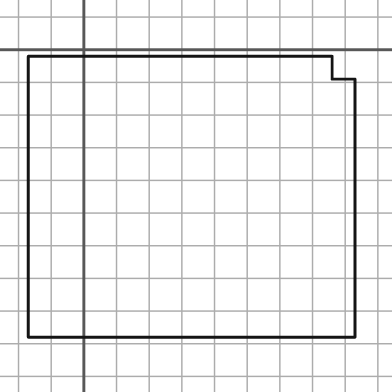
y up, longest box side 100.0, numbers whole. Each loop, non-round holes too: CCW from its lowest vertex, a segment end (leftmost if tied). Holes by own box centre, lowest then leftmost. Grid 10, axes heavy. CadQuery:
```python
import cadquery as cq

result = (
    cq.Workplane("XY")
    .moveTo(-17.0, -88.0)
    .lineTo(83.0, -88.0)
    .lineTo(83.0, -9.0)
    .lineTo(76.0, -9.0)
    .lineTo(76.0, -2.0)
    .lineTo(-17.0, -2.0)
    .close()
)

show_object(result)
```